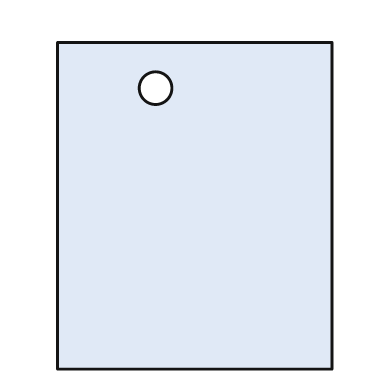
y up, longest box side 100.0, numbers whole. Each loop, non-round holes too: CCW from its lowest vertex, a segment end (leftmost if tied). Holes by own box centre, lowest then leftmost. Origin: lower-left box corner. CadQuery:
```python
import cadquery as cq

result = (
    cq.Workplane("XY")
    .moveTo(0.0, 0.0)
    .lineTo(84.0, 0.0)
    .lineTo(84.0, 100.0)
    .lineTo(0.0, 100.0)
    .close()
    .moveTo(30.0, 86.0)
    .circle(5.0)
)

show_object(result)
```